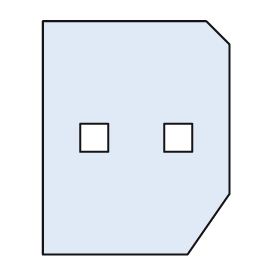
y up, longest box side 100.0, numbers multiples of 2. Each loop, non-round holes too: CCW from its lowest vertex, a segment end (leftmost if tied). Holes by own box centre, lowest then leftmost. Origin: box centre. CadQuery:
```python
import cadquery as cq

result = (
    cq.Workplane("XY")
    .moveTo(-40.0, -50.0)
    .lineTo(22.0, -50.0)
    .lineTo(40.0, -24.0)
    .lineTo(40.0, 40.0)
    .lineTo(30.0, 50.0)
    .lineTo(-40.0, 50.0)
    .close()
    .moveTo(-24.0, -6.0)
    .lineTo(-12.0, -6.0)
    .lineTo(-12.0, 6.0)
    .lineTo(-24.0, 6.0)
    .close()
    .moveTo(12.0, -6.0)
    .lineTo(24.0, -6.0)
    .lineTo(24.0, 6.0)
    .lineTo(12.0, 6.0)
    .close()
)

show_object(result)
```